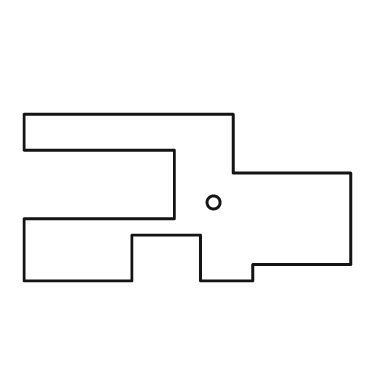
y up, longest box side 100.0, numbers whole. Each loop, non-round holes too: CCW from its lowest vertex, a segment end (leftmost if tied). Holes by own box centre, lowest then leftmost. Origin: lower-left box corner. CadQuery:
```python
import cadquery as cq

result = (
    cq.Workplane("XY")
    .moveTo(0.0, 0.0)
    .lineTo(33.0, 0.0)
    .lineTo(33.0, 14.0)
    .lineTo(54.0, 14.0)
    .lineTo(54.0, 0.0)
    .lineTo(70.0, 0.0)
    .lineTo(70.0, 5.0)
    .lineTo(100.0, 5.0)
    .lineTo(100.0, 33.0)
    .lineTo(64.0, 33.0)
    .lineTo(64.0, 51.0)
    .lineTo(0.0, 51.0)
    .lineTo(0.0, 40.0)
    .lineTo(46.0, 40.0)
    .lineTo(46.0, 19.0)
    .lineTo(0.0, 19.0)
    .close()
    .moveTo(58.0, 24.0)
    .circle(2.0)
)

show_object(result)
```